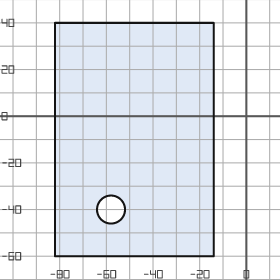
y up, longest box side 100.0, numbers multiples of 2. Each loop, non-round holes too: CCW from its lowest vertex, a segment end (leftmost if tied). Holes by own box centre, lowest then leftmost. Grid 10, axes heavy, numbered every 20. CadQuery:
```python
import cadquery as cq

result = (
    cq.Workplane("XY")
    .moveTo(-82.0, -60.0)
    .lineTo(-14.0, -60.0)
    .lineTo(-14.0, 40.0)
    .lineTo(-82.0, 40.0)
    .close()
    .moveTo(-58.0, -40.0)
    .circle(6.0)
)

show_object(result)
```